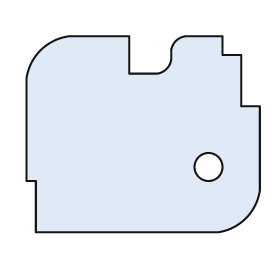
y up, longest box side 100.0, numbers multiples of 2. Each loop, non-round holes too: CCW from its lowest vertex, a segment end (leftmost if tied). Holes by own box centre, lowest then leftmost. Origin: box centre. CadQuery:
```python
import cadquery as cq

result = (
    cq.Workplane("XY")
    .moveTo(-46.0, -42.0)
    .lineTo(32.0, -42.0)
    .threePointArc((44.0, -36.0), (50.0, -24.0))
    .lineTo(50.0, 12.0)
    .lineTo(42.0, 12.0)
    .lineTo(42.0, 34.0)
    .lineTo(34.0, 34.0)
    .lineTo(34.0, 42.0)
    .lineTo(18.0, 42.0)
    .threePointArc((14.0, 40.0), (12.0, 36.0))
    .lineTo(12.0, 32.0)
    .threePointArc((10.0, 28.0), (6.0, 26.0))
    .lineTo(-6.0, 26.0)
    .lineTo(-6.0, 42.0)
    .lineTo(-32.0, 42.0)
    .threePointArc((-44.0, 36.0), (-50.0, 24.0))
    .lineTo(-50.0, -20.0)
    .lineTo(-46.0, -20.0)
    .close()
    .moveTo(28.0, -14.0)
    .circle(6.0)
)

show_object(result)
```